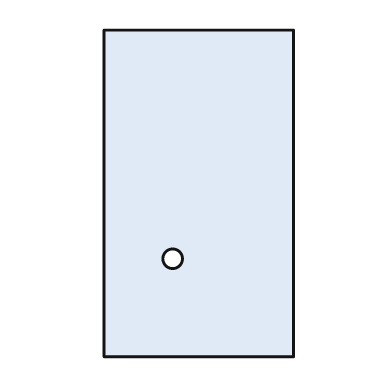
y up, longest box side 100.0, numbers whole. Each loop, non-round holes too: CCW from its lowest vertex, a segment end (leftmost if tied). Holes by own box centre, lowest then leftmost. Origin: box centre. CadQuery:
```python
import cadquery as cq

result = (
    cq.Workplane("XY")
    .moveTo(-29.0, -50.0)
    .lineTo(29.0, -50.0)
    .lineTo(29.0, 50.0)
    .lineTo(-29.0, 50.0)
    .close()
    .moveTo(-8.0, -20.0)
    .circle(3.0)
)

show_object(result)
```